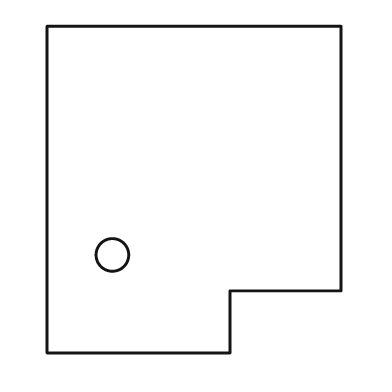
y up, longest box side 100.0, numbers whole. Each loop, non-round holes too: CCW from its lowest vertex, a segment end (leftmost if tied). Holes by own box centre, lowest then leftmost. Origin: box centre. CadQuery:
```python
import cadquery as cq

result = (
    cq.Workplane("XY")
    .moveTo(-45.0, -50.0)
    .lineTo(11.0, -50.0)
    .lineTo(11.0, -31.0)
    .lineTo(45.0, -31.0)
    .lineTo(45.0, 50.0)
    .lineTo(-45.0, 50.0)
    .close()
    .moveTo(-25.0, -20.0)
    .circle(5.0)
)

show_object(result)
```